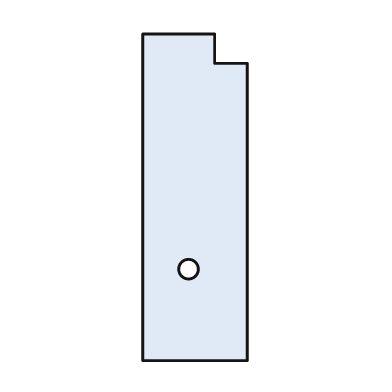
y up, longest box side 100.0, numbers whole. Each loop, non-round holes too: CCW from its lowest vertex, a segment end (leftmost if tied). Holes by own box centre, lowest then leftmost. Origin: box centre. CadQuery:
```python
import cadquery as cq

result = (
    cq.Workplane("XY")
    .moveTo(-16.0, -50.0)
    .lineTo(16.0, -50.0)
    .lineTo(16.0, 41.0)
    .lineTo(6.0, 41.0)
    .lineTo(6.0, 50.0)
    .lineTo(-16.0, 50.0)
    .close()
    .moveTo(-2.0, -22.0)
    .circle(3.0)
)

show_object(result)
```